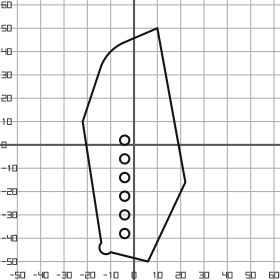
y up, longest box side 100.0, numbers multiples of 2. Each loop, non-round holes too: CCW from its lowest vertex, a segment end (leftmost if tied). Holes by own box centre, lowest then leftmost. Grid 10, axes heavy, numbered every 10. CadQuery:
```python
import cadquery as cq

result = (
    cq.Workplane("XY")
    .moveTo(6.0, -50.0)
    .lineTo(22.0, -16.0)
    .lineTo(10.0, 50.0)
    .lineTo(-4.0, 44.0)
    .threePointArc((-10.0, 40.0), (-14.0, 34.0))
    .lineTo(-22.0, 10.0)
    .lineTo(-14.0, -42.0)
    .threePointArc((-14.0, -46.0), (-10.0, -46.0))
    .close()
    .moveTo(-4.0, -38.0)
    .circle(2.0)
    .moveTo(-4.0, -30.0)
    .circle(2.0)
    .moveTo(-4.0, -22.0)
    .circle(2.0)
    .moveTo(-4.0, -14.0)
    .circle(2.0)
    .moveTo(-4.0, -6.0)
    .circle(2.0)
    .moveTo(-4.0, 2.0)
    .circle(2.0)
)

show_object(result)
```